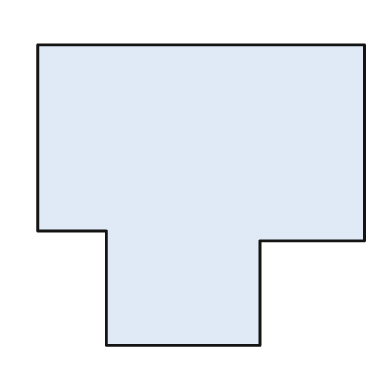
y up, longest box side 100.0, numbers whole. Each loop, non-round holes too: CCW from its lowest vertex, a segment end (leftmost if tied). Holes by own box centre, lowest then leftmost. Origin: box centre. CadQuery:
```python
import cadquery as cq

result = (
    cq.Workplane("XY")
    .moveTo(-29.0, -46.0)
    .lineTo(18.0, -46.0)
    .lineTo(18.0, -14.0)
    .lineTo(50.0, -14.0)
    .lineTo(50.0, 46.0)
    .lineTo(-50.0, 46.0)
    .lineTo(-50.0, -11.0)
    .lineTo(-29.0, -11.0)
    .close()
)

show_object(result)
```